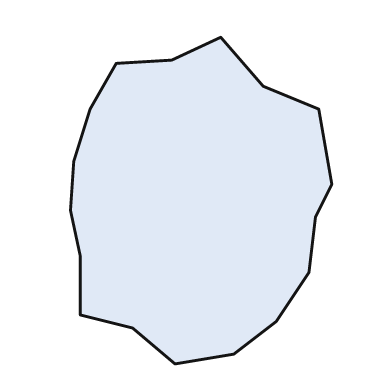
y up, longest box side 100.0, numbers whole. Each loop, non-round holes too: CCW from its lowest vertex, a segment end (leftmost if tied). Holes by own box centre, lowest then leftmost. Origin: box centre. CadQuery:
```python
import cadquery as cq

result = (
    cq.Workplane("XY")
    .moveTo(-8.0, -50.0)
    .lineTo(10.0, -47.0)
    .lineTo(23.0, -37.0)
    .lineTo(33.0, -22.0)
    .lineTo(35.0, -5.0)
    .lineTo(40.0, 5.0)
    .lineTo(36.0, 28.0)
    .lineTo(19.0, 35.0)
    .lineTo(6.0, 50.0)
    .lineTo(-9.0, 43.0)
    .lineTo(-26.0, 42.0)
    .lineTo(-34.0, 28.0)
    .lineTo(-39.0, 12.0)
    .lineTo(-40.0, -3.0)
    .lineTo(-37.0, -17.0)
    .lineTo(-37.0, -35.0)
    .lineTo(-21.0, -39.0)
    .close()
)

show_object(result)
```